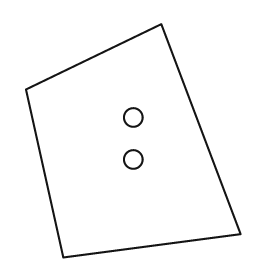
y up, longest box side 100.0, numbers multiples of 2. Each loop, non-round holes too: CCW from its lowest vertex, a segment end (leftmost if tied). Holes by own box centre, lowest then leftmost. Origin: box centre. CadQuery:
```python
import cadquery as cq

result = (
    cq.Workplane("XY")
    .moveTo(-30.0, -50.0)
    .lineTo(46.0, -40.0)
    .lineTo(12.0, 50.0)
    .lineTo(-46.0, 22.0)
    .close()
    .moveTo(0.0, -8.0)
    .circle(4.0)
    .moveTo(0.0, 10.0)
    .circle(4.0)
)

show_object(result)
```